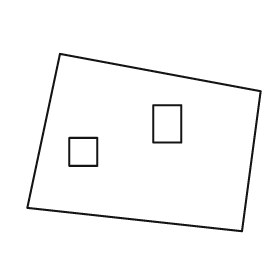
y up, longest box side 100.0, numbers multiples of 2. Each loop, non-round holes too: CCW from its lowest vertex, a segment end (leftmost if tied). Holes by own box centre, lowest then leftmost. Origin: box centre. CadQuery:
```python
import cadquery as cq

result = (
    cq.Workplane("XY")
    .moveTo(42.0, -38.0)
    .lineTo(50.0, 22.0)
    .lineTo(-36.0, 38.0)
    .lineTo(-50.0, -28.0)
    .close()
    .moveTo(-32.0, -10.0)
    .lineTo(-20.0, -10.0)
    .lineTo(-20.0, 2.0)
    .lineTo(-32.0, 2.0)
    .close()
    .moveTo(4.0, 0.0)
    .lineTo(16.0, 0.0)
    .lineTo(16.0, 16.0)
    .lineTo(4.0, 16.0)
    .close()
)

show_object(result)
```